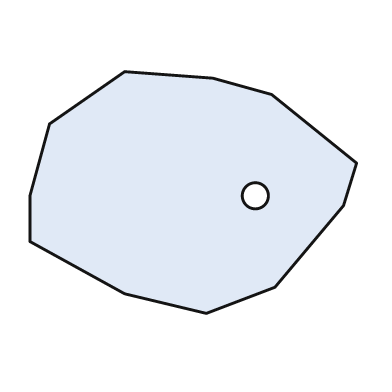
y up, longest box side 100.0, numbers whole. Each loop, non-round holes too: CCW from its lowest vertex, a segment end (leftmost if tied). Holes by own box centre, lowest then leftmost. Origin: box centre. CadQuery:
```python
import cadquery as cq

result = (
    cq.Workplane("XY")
    .moveTo(4.0, -37.0)
    .lineTo(25.0, -29.0)
    .lineTo(46.0, -4.0)
    .lineTo(50.0, 9.0)
    .lineTo(24.0, 30.0)
    .lineTo(6.0, 35.0)
    .lineTo(-21.0, 37.0)
    .lineTo(-44.0, 21.0)
    .lineTo(-50.0, -1.0)
    .lineTo(-50.0, -15.0)
    .lineTo(-21.0, -31.0)
    .close()
    .moveTo(19.0, -1.0)
    .circle(4.0)
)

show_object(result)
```